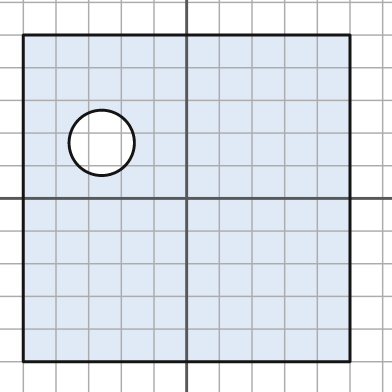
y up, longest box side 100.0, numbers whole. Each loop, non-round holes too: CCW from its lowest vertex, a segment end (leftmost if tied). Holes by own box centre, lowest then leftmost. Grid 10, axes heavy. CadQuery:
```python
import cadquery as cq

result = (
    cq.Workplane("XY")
    .moveTo(-50.0, -50.0)
    .lineTo(50.0, -50.0)
    .lineTo(50.0, 50.0)
    .lineTo(-50.0, 50.0)
    .close()
    .moveTo(-26.0, 17.0)
    .circle(10.0)
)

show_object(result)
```